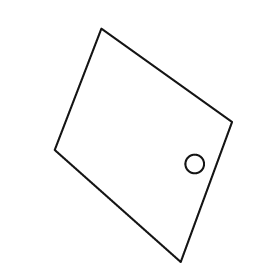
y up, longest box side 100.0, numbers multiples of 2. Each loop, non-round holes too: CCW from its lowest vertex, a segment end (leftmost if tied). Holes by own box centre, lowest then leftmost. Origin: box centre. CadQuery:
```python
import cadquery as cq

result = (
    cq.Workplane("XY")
    .moveTo(16.0, -50.0)
    .lineTo(38.0, 10.0)
    .lineTo(-18.0, 50.0)
    .lineTo(-38.0, -2.0)
    .close()
    .moveTo(22.0, -8.0)
    .circle(4.0)
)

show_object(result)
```